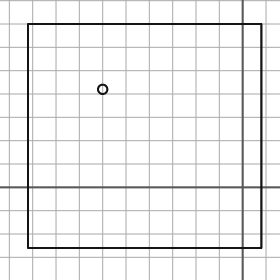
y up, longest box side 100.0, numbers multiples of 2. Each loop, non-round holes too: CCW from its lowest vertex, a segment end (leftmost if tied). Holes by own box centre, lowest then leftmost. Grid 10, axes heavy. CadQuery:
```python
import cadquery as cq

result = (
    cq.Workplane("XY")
    .moveTo(-92.0, -26.0)
    .lineTo(8.0, -26.0)
    .lineTo(8.0, 70.0)
    .lineTo(-92.0, 70.0)
    .close()
    .moveTo(-60.0, 42.0)
    .circle(2.0)
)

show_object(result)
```